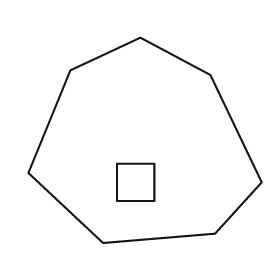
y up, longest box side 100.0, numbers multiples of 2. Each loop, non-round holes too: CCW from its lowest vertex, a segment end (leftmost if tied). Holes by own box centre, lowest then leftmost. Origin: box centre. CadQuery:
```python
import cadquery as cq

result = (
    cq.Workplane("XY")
    .moveTo(-18.0, -44.0)
    .lineTo(30.0, -40.0)
    .lineTo(50.0, -18.0)
    .lineTo(28.0, 28.0)
    .lineTo(-2.0, 44.0)
    .lineTo(-32.0, 30.0)
    .lineTo(-50.0, -14.0)
    .close()
    .moveTo(-12.0, -26.0)
    .lineTo(4.0, -26.0)
    .lineTo(4.0, -10.0)
    .lineTo(-12.0, -10.0)
    .close()
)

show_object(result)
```